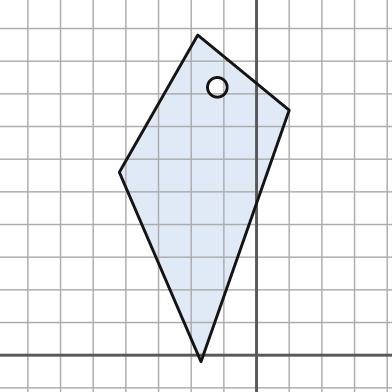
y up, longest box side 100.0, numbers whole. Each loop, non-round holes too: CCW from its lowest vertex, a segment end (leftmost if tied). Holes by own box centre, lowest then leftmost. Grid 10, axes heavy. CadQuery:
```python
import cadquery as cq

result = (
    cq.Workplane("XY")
    .moveTo(-17.0, -2.0)
    .lineTo(10.0, 75.0)
    .lineTo(-18.0, 98.0)
    .lineTo(-42.0, 56.0)
    .close()
    .moveTo(-12.0, 82.0)
    .circle(3.0)
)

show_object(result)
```